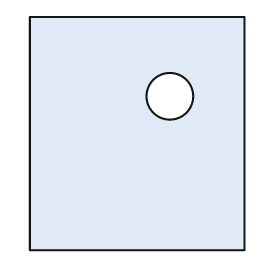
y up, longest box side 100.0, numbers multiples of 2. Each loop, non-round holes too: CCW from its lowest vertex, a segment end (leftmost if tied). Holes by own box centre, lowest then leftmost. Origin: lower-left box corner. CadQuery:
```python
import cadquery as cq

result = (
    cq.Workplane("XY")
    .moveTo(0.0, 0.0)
    .lineTo(92.0, 0.0)
    .lineTo(92.0, 100.0)
    .lineTo(0.0, 100.0)
    .close()
    .moveTo(60.0, 66.0)
    .circle(10.0)
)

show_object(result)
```